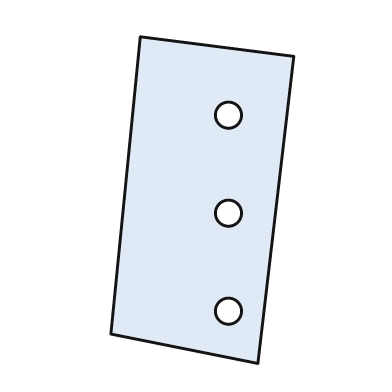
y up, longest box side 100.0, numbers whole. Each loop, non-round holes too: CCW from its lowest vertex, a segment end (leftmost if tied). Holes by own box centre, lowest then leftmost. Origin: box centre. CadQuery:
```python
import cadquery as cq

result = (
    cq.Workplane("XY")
    .moveTo(17.0, -50.0)
    .lineTo(28.0, 44.0)
    .lineTo(-19.0, 50.0)
    .lineTo(-28.0, -41.0)
    .close()
    .moveTo(8.0, -34.0)
    .circle(4.0)
    .moveTo(8.0, -4.0)
    .circle(4.0)
    .moveTo(8.0, 26.0)
    .circle(4.0)
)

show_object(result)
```